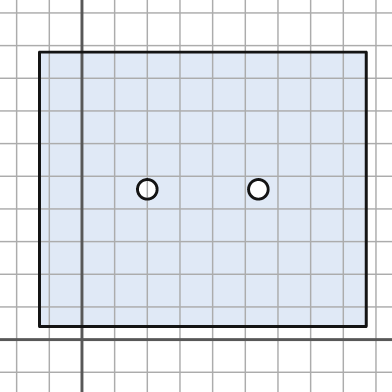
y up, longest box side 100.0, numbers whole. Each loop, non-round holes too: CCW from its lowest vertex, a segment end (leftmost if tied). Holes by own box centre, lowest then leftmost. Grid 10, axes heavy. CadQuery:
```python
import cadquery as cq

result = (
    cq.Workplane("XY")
    .moveTo(-13.0, 4.0)
    .lineTo(87.0, 4.0)
    .lineTo(87.0, 88.0)
    .lineTo(-13.0, 88.0)
    .close()
    .moveTo(20.0, 46.0)
    .circle(3.0)
    .moveTo(54.0, 46.0)
    .circle(3.0)
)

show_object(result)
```